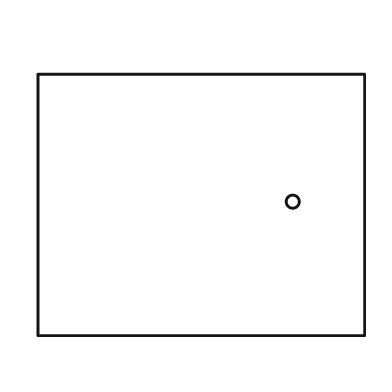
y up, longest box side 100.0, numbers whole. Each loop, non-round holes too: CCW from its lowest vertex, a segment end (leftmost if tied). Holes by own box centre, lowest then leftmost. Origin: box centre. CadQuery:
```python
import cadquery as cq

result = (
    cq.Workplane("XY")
    .moveTo(-50.0, -40.0)
    .lineTo(50.0, -40.0)
    .lineTo(50.0, 40.0)
    .lineTo(-50.0, 40.0)
    .close()
    .moveTo(28.0, 1.0)
    .circle(2.0)
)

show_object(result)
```